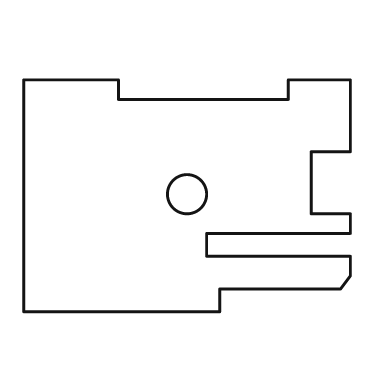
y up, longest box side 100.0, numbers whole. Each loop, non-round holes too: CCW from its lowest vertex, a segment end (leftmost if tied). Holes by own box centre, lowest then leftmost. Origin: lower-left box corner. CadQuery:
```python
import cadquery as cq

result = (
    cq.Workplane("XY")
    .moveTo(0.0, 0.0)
    .lineTo(60.0, 0.0)
    .lineTo(60.0, 7.0)
    .lineTo(97.0, 7.0)
    .lineTo(100.0, 11.0)
    .lineTo(100.0, 17.0)
    .lineTo(56.0, 17.0)
    .lineTo(56.0, 24.0)
    .lineTo(100.0, 24.0)
    .lineTo(100.0, 30.0)
    .lineTo(88.0, 30.0)
    .lineTo(88.0, 49.0)
    .lineTo(100.0, 49.0)
    .lineTo(100.0, 71.0)
    .lineTo(81.0, 71.0)
    .lineTo(81.0, 65.0)
    .lineTo(29.0, 65.0)
    .lineTo(29.0, 71.0)
    .lineTo(0.0, 71.0)
    .close()
    .moveTo(50.0, 36.0)
    .circle(6.0)
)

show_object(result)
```